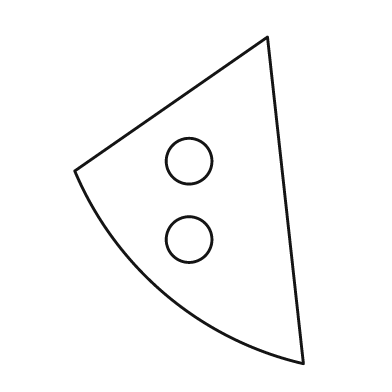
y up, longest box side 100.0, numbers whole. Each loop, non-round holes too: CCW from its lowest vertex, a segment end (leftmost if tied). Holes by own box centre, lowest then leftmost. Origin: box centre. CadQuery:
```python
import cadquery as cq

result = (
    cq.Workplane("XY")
    .moveTo(35.0, -50.0)
    .lineTo(24.0, 50.0)
    .lineTo(-35.0, 9.0)
    .threePointArc((-7.0, -29.0), (35.0, -50.0))
    .close()
    .moveTo(0.0, -12.0)
    .circle(7.0)
    .moveTo(0.0, 12.0)
    .circle(7.0)
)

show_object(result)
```